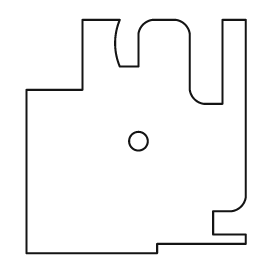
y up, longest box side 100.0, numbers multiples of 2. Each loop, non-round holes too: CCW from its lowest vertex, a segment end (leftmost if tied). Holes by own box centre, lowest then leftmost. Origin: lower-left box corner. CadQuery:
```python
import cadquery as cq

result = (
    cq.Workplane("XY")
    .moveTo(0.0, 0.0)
    .lineTo(56.0, 0.0)
    .lineTo(56.0, 4.0)
    .lineTo(94.0, 4.0)
    .lineTo(94.0, 8.0)
    .lineTo(80.0, 8.0)
    .lineTo(80.0, 18.0)
    .lineTo(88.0, 18.0)
    .threePointArc((92.0, 20.0), (94.0, 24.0))
    .lineTo(94.0, 100.0)
    .lineTo(84.0, 100.0)
    .lineTo(84.0, 64.0)
    .lineTo(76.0, 64.0)
    .threePointArc((72.0, 66.0), (70.0, 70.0))
    .lineTo(70.0, 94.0)
    .threePointArc((68.0, 98.0), (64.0, 100.0))
    .lineTo(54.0, 100.0)
    .threePointArc((50.0, 98.0), (48.0, 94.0))
    .lineTo(48.0, 80.0)
    .lineTo(40.0, 80.0)
    .threePointArc((38.0, 90.0), (40.0, 100.0))
    .lineTo(24.0, 100.0)
    .lineTo(24.0, 70.0)
    .lineTo(0.0, 70.0)
    .close()
    .moveTo(48.0, 48.0)
    .circle(4.0)
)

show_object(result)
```